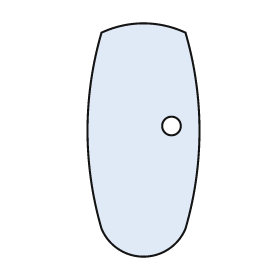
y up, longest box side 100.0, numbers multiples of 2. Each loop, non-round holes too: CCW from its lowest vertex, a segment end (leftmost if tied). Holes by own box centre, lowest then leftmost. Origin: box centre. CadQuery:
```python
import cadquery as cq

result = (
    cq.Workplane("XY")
    .moveTo(-18.0, -38.0)
    .threePointArc((0.0, -50.0), (18.0, -38.0))
    .threePointArc((24.0, 4.0), (18.0, 46.0))
    .threePointArc((0.0, 50.0), (-18.0, 46.0))
    .threePointArc((-24.0, 4.0), (-18.0, -38.0))
    .close()
    .moveTo(12.0, 6.0)
    .circle(4.0)
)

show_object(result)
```